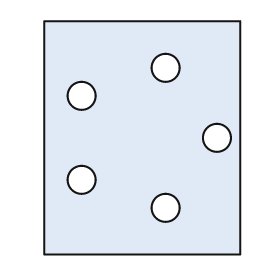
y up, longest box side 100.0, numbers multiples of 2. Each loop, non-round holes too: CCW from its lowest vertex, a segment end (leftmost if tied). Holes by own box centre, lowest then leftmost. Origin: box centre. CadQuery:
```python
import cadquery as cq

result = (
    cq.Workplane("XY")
    .moveTo(-42.0, -50.0)
    .lineTo(42.0, -50.0)
    .lineTo(42.0, 50.0)
    .lineTo(-42.0, 50.0)
    .close()
    .moveTo(10.0, -30.0)
    .circle(6.0)
    .moveTo(-26.0, -18.0)
    .circle(6.0)
    .moveTo(32.0, 0.0)
    .circle(6.0)
    .moveTo(-26.0, 18.0)
    .circle(6.0)
    .moveTo(10.0, 30.0)
    .circle(6.0)
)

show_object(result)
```